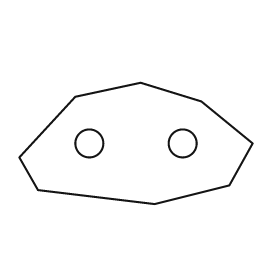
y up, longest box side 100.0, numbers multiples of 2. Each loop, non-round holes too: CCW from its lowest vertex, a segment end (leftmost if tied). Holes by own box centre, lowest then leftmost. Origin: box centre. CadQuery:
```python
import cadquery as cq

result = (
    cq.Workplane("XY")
    .moveTo(8.0, -26.0)
    .lineTo(40.0, -18.0)
    .lineTo(50.0, 0.0)
    .lineTo(28.0, 18.0)
    .lineTo(2.0, 26.0)
    .lineTo(-26.0, 20.0)
    .lineTo(-50.0, -6.0)
    .lineTo(-42.0, -20.0)
    .close()
    .moveTo(-20.0, 0.0)
    .circle(6.0)
    .moveTo(20.0, 0.0)
    .circle(6.0)
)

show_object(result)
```